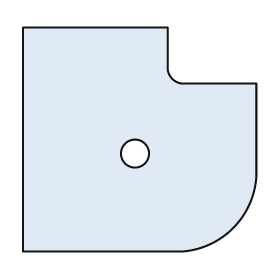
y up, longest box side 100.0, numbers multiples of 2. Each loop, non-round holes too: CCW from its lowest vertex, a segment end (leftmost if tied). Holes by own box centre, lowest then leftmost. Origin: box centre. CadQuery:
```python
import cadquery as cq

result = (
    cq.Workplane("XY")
    .moveTo(-50.0, -48.0)
    .lineTo(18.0, -48.0)
    .threePointArc((40.0, -38.0), (50.0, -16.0))
    .lineTo(50.0, 24.0)
    .lineTo(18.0, 24.0)
    .threePointArc((14.0, 26.0), (12.0, 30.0))
    .lineTo(12.0, 48.0)
    .lineTo(-50.0, 48.0)
    .close()
    .moveTo(-2.0, -6.0)
    .circle(6.0)
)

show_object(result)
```